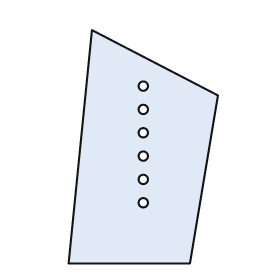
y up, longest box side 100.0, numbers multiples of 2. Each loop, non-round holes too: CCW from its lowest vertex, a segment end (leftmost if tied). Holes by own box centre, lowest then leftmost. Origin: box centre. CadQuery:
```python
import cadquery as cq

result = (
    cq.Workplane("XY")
    .moveTo(-32.0, -50.0)
    .lineTo(20.0, -50.0)
    .lineTo(32.0, 22.0)
    .lineTo(-22.0, 50.0)
    .close()
    .moveTo(0.0, -24.0)
    .circle(2.0)
    .moveTo(0.0, -14.0)
    .circle(2.0)
    .moveTo(0.0, -4.0)
    .circle(2.0)
    .moveTo(0.0, 6.0)
    .circle(2.0)
    .moveTo(0.0, 16.0)
    .circle(2.0)
    .moveTo(0.0, 26.0)
    .circle(2.0)
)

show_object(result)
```